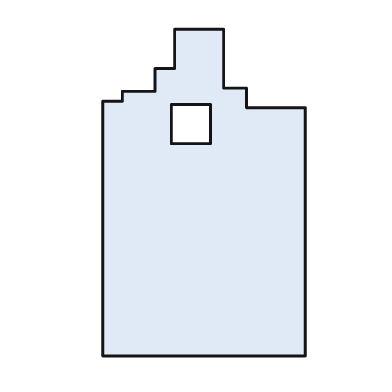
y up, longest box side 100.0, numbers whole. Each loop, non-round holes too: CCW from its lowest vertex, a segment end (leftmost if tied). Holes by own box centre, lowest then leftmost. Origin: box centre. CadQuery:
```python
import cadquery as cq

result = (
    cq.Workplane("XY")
    .moveTo(-31.0, -50.0)
    .lineTo(31.0, -50.0)
    .lineTo(31.0, 26.0)
    .lineTo(13.0, 26.0)
    .lineTo(13.0, 32.0)
    .lineTo(6.0, 32.0)
    .lineTo(6.0, 50.0)
    .lineTo(-9.0, 50.0)
    .lineTo(-9.0, 38.0)
    .lineTo(-15.0, 38.0)
    .lineTo(-15.0, 31.0)
    .lineTo(-25.0, 31.0)
    .lineTo(-25.0, 28.0)
    .lineTo(-31.0, 28.0)
    .close()
    .moveTo(-10.0, 15.0)
    .lineTo(2.0, 15.0)
    .lineTo(2.0, 27.0)
    .lineTo(-10.0, 27.0)
    .close()
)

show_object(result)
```